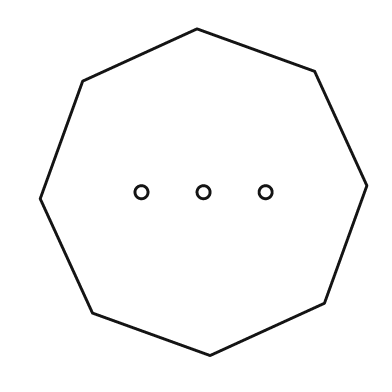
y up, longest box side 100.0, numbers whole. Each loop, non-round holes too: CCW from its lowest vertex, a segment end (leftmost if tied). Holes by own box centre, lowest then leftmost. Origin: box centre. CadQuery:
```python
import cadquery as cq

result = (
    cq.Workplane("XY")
    .moveTo(2.0, -50.0)
    .lineTo(37.0, -34.0)
    .lineTo(50.0, 2.0)
    .lineTo(34.0, 37.0)
    .lineTo(-2.0, 50.0)
    .lineTo(-37.0, 34.0)
    .lineTo(-50.0, -2.0)
    .lineTo(-34.0, -37.0)
    .close()
    .moveTo(-19.0, 0.0)
    .circle(2.0)
    .moveTo(0.0, 0.0)
    .circle(2.0)
    .moveTo(19.0, 0.0)
    .circle(2.0)
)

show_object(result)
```